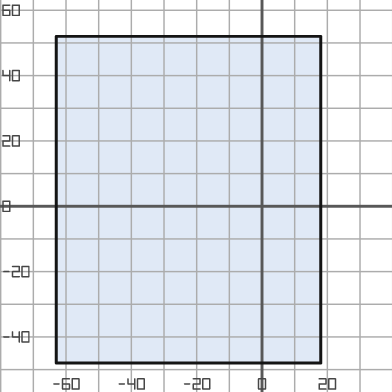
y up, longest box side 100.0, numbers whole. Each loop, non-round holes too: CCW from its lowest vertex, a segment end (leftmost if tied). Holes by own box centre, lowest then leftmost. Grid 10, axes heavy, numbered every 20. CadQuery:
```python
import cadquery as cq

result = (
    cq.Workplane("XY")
    .moveTo(-63.0, -48.0)
    .lineTo(18.0, -48.0)
    .lineTo(18.0, 52.0)
    .lineTo(-63.0, 52.0)
    .close()
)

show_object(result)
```